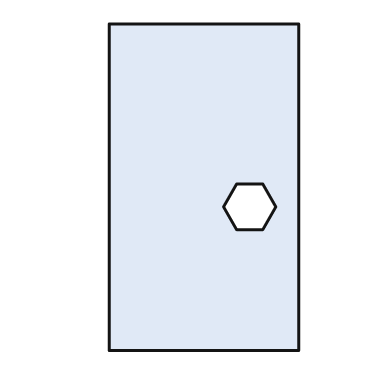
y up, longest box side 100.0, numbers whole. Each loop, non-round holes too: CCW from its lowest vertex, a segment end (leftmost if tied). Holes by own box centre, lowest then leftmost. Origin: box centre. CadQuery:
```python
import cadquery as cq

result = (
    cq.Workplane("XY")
    .moveTo(-29.0, -50.0)
    .lineTo(29.0, -50.0)
    .lineTo(29.0, 50.0)
    .lineTo(-29.0, 50.0)
    .close()
    .moveTo(10.0, -13.0)
    .lineTo(18.0, -13.0)
    .lineTo(22.0, -6.0)
    .lineTo(18.0, 1.0)
    .lineTo(10.0, 1.0)
    .lineTo(6.0, -6.0)
    .close()
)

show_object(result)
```